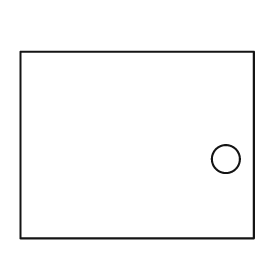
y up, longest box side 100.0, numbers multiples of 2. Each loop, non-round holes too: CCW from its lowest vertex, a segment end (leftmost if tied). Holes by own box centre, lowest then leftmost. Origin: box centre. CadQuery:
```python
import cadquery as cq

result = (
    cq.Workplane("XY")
    .moveTo(-50.0, -40.0)
    .lineTo(50.0, -40.0)
    .lineTo(50.0, 40.0)
    .lineTo(-50.0, 40.0)
    .close()
    .moveTo(38.0, -6.0)
    .circle(6.0)
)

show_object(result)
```